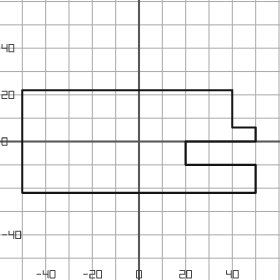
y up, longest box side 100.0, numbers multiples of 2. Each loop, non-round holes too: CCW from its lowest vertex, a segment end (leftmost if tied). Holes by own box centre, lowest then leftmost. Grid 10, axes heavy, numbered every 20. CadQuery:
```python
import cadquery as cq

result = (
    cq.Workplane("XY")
    .moveTo(-50.0, -22.0)
    .lineTo(50.0, -22.0)
    .lineTo(50.0, -10.0)
    .lineTo(20.0, -10.0)
    .lineTo(20.0, 0.0)
    .lineTo(50.0, 0.0)
    .lineTo(50.0, 6.0)
    .lineTo(40.0, 6.0)
    .lineTo(40.0, 22.0)
    .lineTo(-50.0, 22.0)
    .close()
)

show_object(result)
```